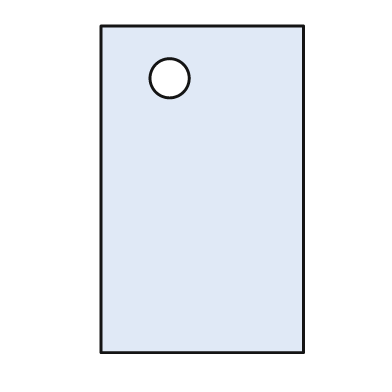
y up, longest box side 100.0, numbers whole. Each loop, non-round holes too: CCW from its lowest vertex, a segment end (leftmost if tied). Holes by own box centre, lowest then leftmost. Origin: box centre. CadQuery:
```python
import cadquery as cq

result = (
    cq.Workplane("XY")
    .moveTo(-31.0, -50.0)
    .lineTo(31.0, -50.0)
    .lineTo(31.0, 50.0)
    .lineTo(-31.0, 50.0)
    .close()
    .moveTo(-10.0, 34.0)
    .circle(6.0)
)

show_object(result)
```